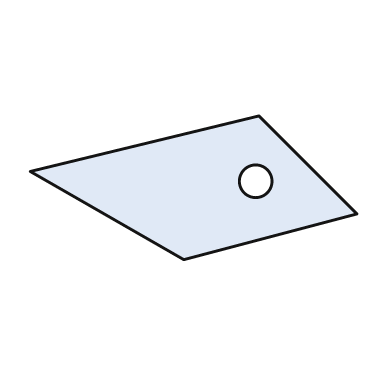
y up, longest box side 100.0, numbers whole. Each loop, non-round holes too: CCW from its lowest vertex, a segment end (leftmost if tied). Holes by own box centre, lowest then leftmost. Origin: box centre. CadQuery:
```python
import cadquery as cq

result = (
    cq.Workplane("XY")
    .moveTo(-3.0, -22.0)
    .lineTo(50.0, -8.0)
    .lineTo(20.0, 22.0)
    .lineTo(-50.0, 5.0)
    .close()
    .moveTo(19.0, 2.0)
    .circle(5.0)
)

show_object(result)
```